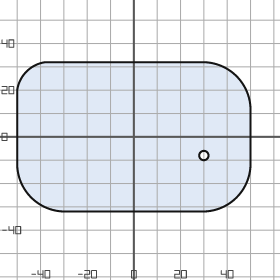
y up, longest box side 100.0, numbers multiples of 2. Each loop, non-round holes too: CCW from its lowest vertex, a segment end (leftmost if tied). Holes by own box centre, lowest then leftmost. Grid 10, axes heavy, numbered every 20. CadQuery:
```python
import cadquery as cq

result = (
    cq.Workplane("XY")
    .moveTo(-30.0, -32.0)
    .lineTo(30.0, -32.0)
    .threePointArc((44.0, -26.0), (50.0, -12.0))
    .lineTo(50.0, 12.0)
    .threePointArc((44.0, 26.0), (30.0, 32.0))
    .lineTo(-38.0, 32.0)
    .threePointArc((-46.0, 28.0), (-50.0, 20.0))
    .lineTo(-50.0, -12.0)
    .threePointArc((-44.0, -26.0), (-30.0, -32.0))
    .close()
    .moveTo(30.0, -8.0)
    .circle(2.0)
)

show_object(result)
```